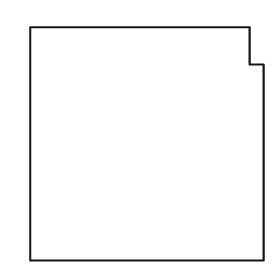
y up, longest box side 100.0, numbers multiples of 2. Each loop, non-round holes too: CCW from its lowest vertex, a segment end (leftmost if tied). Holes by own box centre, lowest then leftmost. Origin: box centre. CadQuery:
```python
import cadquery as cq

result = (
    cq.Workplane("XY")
    .moveTo(-50.0, -50.0)
    .lineTo(50.0, -50.0)
    .lineTo(50.0, 34.0)
    .lineTo(44.0, 34.0)
    .lineTo(44.0, 50.0)
    .lineTo(-50.0, 50.0)
    .close()
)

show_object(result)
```